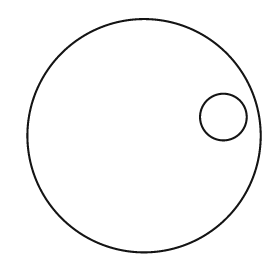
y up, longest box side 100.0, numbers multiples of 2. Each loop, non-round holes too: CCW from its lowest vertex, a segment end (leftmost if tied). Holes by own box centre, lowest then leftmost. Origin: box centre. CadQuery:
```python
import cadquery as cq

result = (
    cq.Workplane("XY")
    .moveTo(0.0, 0.0)
    .circle(50.0)
    .moveTo(34.0, 8.0)
    .circle(10.0)
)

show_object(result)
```